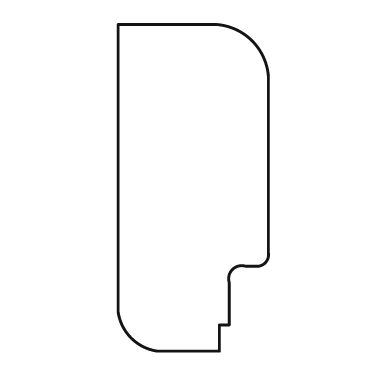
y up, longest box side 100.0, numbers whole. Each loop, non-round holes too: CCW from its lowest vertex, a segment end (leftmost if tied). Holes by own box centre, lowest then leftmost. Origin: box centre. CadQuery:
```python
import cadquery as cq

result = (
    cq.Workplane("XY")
    .moveTo(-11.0, -50.0)
    .lineTo(8.0, -50.0)
    .lineTo(8.0, -42.0)
    .lineTo(11.0, -42.0)
    .lineTo(11.0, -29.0)
    .threePointArc((12.0, -25.0), (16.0, -24.0))
    .lineTo(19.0, -24.0)
    .threePointArc((22.0, -23.0), (23.0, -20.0))
    .lineTo(23.0, 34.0)
    .threePointArc((18.0, 45.0), (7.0, 50.0))
    .lineTo(-23.0, 50.0)
    .lineTo(-23.0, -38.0)
    .threePointArc((-19.0, -46.0), (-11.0, -50.0))
    .close()
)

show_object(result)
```